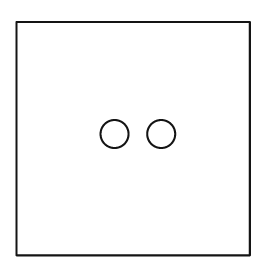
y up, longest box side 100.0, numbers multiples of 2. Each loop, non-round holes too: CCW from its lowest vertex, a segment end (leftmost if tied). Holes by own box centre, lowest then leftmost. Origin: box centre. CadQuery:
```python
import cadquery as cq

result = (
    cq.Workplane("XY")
    .moveTo(-50.0, -50.0)
    .lineTo(50.0, -50.0)
    .lineTo(50.0, 50.0)
    .lineTo(-50.0, 50.0)
    .close()
    .moveTo(-8.0, 2.0)
    .circle(6.0)
    .moveTo(12.0, 2.0)
    .circle(6.0)
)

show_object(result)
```